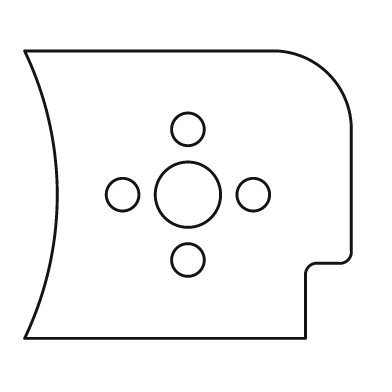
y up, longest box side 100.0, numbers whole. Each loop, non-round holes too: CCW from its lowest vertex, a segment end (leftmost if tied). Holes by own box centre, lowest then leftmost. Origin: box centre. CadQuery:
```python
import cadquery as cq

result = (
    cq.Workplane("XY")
    .moveTo(-50.0, -44.0)
    .lineTo(36.0, -44.0)
    .lineTo(36.0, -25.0)
    .threePointArc((37.0, -22.0), (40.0, -21.0))
    .lineTo(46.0, -21.0)
    .threePointArc((49.0, -20.0), (50.0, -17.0))
    .lineTo(50.0, 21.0)
    .threePointArc((43.0, 37.0), (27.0, 44.0))
    .lineTo(-50.0, 44.0)
    .threePointArc((-40.0, 0.0), (-50.0, -44.0))
    .close()
    .moveTo(0.0, -20.0)
    .circle(5.0)
    .moveTo(-20.0, 0.0)
    .circle(5.0)
    .moveTo(0.0, 0.0)
    .circle(10.0)
    .moveTo(20.0, 0.0)
    .circle(5.0)
    .moveTo(0.0, 20.0)
    .circle(5.0)
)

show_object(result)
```